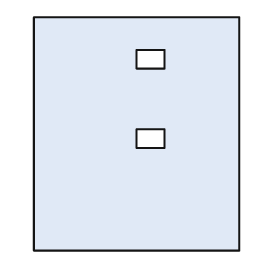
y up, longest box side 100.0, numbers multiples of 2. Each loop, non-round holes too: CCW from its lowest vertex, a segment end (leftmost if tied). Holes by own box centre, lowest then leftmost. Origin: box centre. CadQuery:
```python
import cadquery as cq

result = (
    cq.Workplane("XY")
    .moveTo(-44.0, -50.0)
    .lineTo(44.0, -50.0)
    .lineTo(44.0, 50.0)
    .lineTo(-44.0, 50.0)
    .close()
    .moveTo(0.0, -6.0)
    .lineTo(12.0, -6.0)
    .lineTo(12.0, 2.0)
    .lineTo(0.0, 2.0)
    .close()
    .moveTo(0.0, 28.0)
    .lineTo(12.0, 28.0)
    .lineTo(12.0, 36.0)
    .lineTo(0.0, 36.0)
    .close()
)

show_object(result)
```